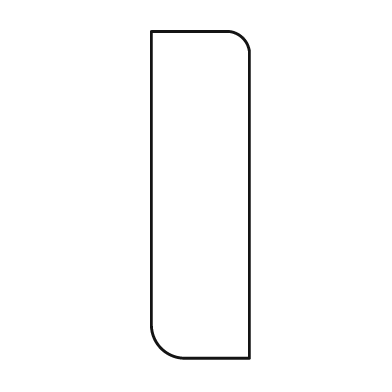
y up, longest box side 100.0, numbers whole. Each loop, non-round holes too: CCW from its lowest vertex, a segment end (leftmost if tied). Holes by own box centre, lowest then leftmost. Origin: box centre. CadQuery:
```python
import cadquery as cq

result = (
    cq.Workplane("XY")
    .moveTo(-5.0, -50.0)
    .lineTo(15.0, -50.0)
    .lineTo(15.0, 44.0)
    .threePointArc((13.0, 48.0), (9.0, 50.0))
    .lineTo(-15.0, 50.0)
    .lineTo(-15.0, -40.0)
    .threePointArc((-12.0, -47.0), (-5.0, -50.0))
    .close()
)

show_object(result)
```